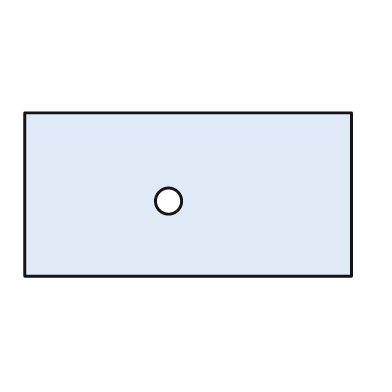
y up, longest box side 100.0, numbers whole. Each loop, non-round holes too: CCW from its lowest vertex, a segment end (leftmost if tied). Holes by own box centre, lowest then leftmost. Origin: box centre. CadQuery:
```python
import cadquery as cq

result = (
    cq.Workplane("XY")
    .moveTo(-50.0, -25.0)
    .lineTo(50.0, -25.0)
    .lineTo(50.0, 25.0)
    .lineTo(-50.0, 25.0)
    .close()
    .moveTo(-6.0, -2.0)
    .circle(4.0)
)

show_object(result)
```